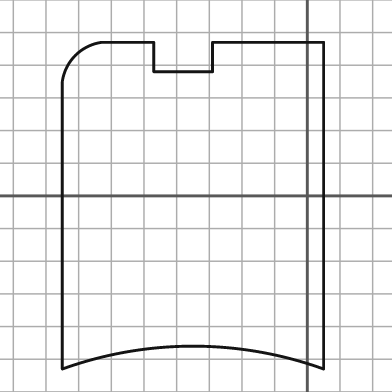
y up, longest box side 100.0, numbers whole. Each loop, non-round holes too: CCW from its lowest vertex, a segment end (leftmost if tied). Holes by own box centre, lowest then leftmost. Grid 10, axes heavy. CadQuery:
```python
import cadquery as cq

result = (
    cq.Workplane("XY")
    .moveTo(-75.0, -53.0)
    .threePointArc((-35.0, -46.0), (5.0, -53.0))
    .lineTo(5.0, 47.0)
    .lineTo(-29.0, 47.0)
    .lineTo(-29.0, 38.0)
    .lineTo(-47.0, 38.0)
    .lineTo(-47.0, 47.0)
    .lineTo(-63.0, 47.0)
    .threePointArc((-71.0, 43.0), (-75.0, 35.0))
    .close()
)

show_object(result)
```